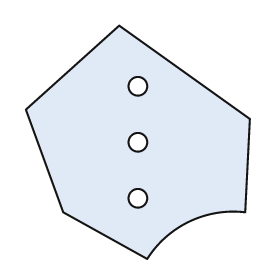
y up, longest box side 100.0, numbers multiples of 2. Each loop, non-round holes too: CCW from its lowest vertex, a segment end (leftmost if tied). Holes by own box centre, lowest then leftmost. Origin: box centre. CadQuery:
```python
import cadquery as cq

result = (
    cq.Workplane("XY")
    .moveTo(4.0, -50.0)
    .threePointArc((22.0, -34.0), (46.0, -30.0))
    .lineTo(48.0, 10.0)
    .lineTo(-8.0, 50.0)
    .lineTo(-48.0, 14.0)
    .lineTo(-32.0, -30.0)
    .close()
    .moveTo(0.0, -24.0)
    .circle(4.0)
    .moveTo(0.0, 0.0)
    .circle(4.0)
    .moveTo(0.0, 24.0)
    .circle(4.0)
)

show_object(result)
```